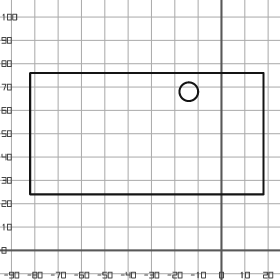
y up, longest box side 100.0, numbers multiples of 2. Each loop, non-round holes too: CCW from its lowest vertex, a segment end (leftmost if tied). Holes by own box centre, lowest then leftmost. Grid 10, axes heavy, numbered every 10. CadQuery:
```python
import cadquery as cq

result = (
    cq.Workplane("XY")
    .moveTo(-82.0, 24.0)
    .lineTo(18.0, 24.0)
    .lineTo(18.0, 76.0)
    .lineTo(-82.0, 76.0)
    .close()
    .moveTo(-14.0, 68.0)
    .circle(4.0)
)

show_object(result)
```